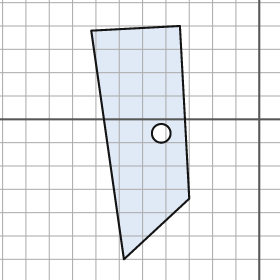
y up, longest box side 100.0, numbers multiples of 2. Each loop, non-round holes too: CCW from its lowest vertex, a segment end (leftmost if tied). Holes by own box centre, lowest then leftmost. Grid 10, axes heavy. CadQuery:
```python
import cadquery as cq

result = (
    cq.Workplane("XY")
    .moveTo(-58.0, -60.0)
    .lineTo(-30.0, -34.0)
    .lineTo(-34.0, 40.0)
    .lineTo(-72.0, 38.0)
    .close()
    .moveTo(-42.0, -6.0)
    .circle(4.0)
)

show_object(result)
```